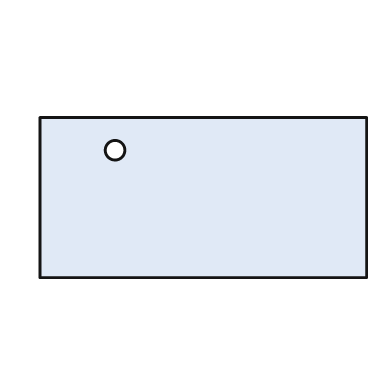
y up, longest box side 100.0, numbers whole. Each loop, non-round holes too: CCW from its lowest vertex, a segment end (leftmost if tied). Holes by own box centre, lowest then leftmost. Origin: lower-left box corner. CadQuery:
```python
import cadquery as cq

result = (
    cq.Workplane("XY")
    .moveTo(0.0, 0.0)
    .lineTo(100.0, 0.0)
    .lineTo(100.0, 49.0)
    .lineTo(0.0, 49.0)
    .close()
    .moveTo(23.0, 39.0)
    .circle(3.0)
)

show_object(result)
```